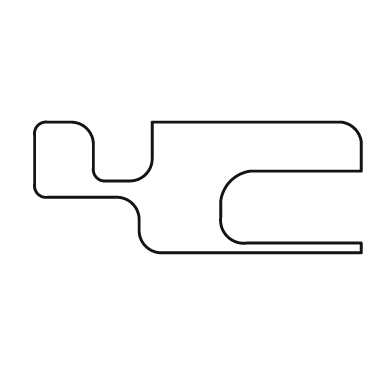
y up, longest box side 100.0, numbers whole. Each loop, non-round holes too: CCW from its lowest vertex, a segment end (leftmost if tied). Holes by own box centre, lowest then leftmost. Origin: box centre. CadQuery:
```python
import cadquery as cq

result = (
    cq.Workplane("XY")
    .moveTo(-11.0, -20.0)
    .lineTo(50.0, -20.0)
    .lineTo(50.0, -17.0)
    .lineTo(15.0, -17.0)
    .threePointArc((9.0, -15.0), (7.0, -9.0))
    .lineTo(7.0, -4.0)
    .threePointArc((10.0, 2.0), (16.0, 5.0))
    .lineTo(50.0, 5.0)
    .lineTo(50.0, 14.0)
    .threePointArc((48.0, 18.0), (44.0, 20.0))
    .lineTo(-14.0, 20.0)
    .lineTo(-14.0, 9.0)
    .threePointArc((-16.0, 4.0), (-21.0, 2.0))
    .lineTo(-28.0, 2.0)
    .threePointArc((-31.0, 3.0), (-32.0, 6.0))
    .lineTo(-32.0, 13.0)
    .threePointArc((-34.0, 18.0), (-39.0, 20.0))
    .lineTo(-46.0, 20.0)
    .threePointArc((-49.0, 19.0), (-50.0, 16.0))
    .lineTo(-50.0, 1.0)
    .threePointArc((-49.0, -2.0), (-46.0, -3.0))
    .lineTo(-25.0, -3.0)
    .threePointArc((-20.0, -5.0), (-18.0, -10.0))
    .lineTo(-18.0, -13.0)
    .threePointArc((-16.0, -18.0), (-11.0, -20.0))
    .close()
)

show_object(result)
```